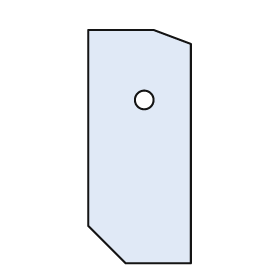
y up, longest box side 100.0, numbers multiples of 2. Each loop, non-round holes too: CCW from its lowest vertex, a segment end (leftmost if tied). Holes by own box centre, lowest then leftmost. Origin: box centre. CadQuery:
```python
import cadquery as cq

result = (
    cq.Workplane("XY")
    .moveTo(-6.0, -50.0)
    .lineTo(22.0, -50.0)
    .lineTo(22.0, 44.0)
    .lineTo(6.0, 50.0)
    .lineTo(-22.0, 50.0)
    .lineTo(-22.0, -34.0)
    .close()
    .moveTo(2.0, 20.0)
    .circle(4.0)
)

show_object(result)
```